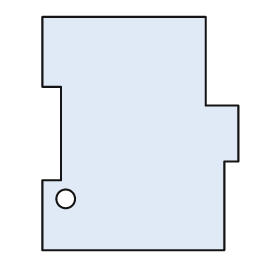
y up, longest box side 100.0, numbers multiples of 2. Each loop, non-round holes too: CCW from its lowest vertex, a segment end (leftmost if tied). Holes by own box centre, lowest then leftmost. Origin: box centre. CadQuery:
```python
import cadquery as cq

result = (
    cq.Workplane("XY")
    .moveTo(-42.0, -50.0)
    .lineTo(36.0, -50.0)
    .lineTo(36.0, -12.0)
    .lineTo(42.0, -12.0)
    .lineTo(42.0, 12.0)
    .lineTo(28.0, 12.0)
    .lineTo(28.0, 50.0)
    .lineTo(-42.0, 50.0)
    .lineTo(-42.0, 20.0)
    .lineTo(-34.0, 20.0)
    .lineTo(-34.0, -20.0)
    .lineTo(-42.0, -20.0)
    .close()
    .moveTo(-32.0, -28.0)
    .circle(4.0)
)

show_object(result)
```